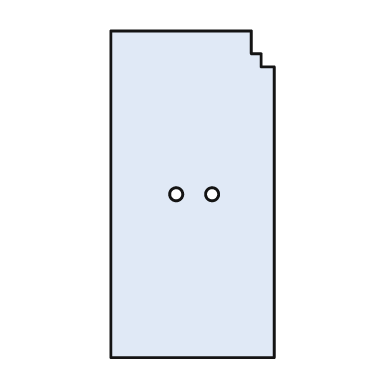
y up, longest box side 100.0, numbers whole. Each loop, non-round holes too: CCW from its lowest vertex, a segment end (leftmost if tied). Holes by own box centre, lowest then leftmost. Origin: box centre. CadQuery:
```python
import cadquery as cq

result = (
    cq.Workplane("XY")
    .moveTo(-25.0, -50.0)
    .lineTo(25.0, -50.0)
    .lineTo(25.0, 39.0)
    .lineTo(21.0, 39.0)
    .lineTo(21.0, 43.0)
    .lineTo(18.0, 43.0)
    .lineTo(18.0, 50.0)
    .lineTo(-25.0, 50.0)
    .close()
    .moveTo(-5.0, 0.0)
    .circle(2.0)
    .moveTo(6.0, 0.0)
    .circle(2.0)
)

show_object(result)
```